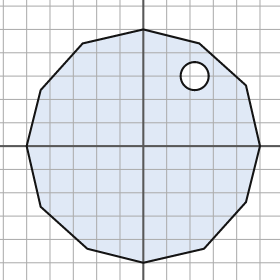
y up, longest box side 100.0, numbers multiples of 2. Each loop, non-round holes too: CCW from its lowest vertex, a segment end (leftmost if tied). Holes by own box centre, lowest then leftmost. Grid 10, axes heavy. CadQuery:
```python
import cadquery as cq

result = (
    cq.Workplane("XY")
    .moveTo(0.0, -50.0)
    .lineTo(26.0, -44.0)
    .lineTo(44.0, -24.0)
    .lineTo(50.0, 0.0)
    .lineTo(44.0, 26.0)
    .lineTo(24.0, 44.0)
    .lineTo(0.0, 50.0)
    .lineTo(-26.0, 44.0)
    .lineTo(-44.0, 24.0)
    .lineTo(-50.0, 0.0)
    .lineTo(-44.0, -26.0)
    .lineTo(-24.0, -44.0)
    .close()
    .moveTo(22.0, 30.0)
    .circle(6.0)
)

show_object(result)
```